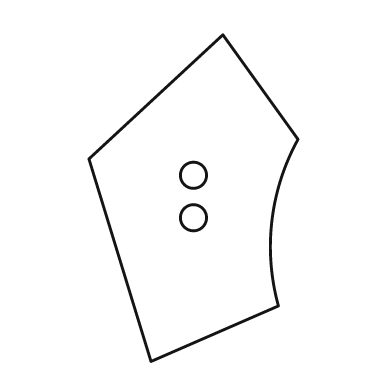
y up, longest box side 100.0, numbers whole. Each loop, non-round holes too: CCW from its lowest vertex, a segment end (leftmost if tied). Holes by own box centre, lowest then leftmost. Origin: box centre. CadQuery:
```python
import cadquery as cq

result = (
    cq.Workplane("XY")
    .moveTo(-13.0, -50.0)
    .lineTo(26.0, -33.0)
    .threePointArc((24.0, -7.0), (32.0, 18.0))
    .lineTo(9.0, 50.0)
    .lineTo(-32.0, 12.0)
    .close()
    .moveTo(0.0, -6.0)
    .circle(4.0)
    .moveTo(0.0, 7.0)
    .circle(4.0)
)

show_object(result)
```